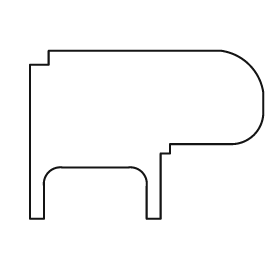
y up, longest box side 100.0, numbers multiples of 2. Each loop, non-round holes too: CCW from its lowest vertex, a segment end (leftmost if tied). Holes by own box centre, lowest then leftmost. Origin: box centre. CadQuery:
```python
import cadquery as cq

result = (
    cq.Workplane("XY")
    .moveTo(-50.0, -36.0)
    .lineTo(-44.0, -36.0)
    .lineTo(-44.0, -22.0)
    .threePointArc((-42.0, -16.0), (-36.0, -14.0))
    .lineTo(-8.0, -14.0)
    .threePointArc((-2.0, -16.0), (0.0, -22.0))
    .lineTo(0.0, -36.0)
    .lineTo(6.0, -36.0)
    .lineTo(6.0, -8.0)
    .lineTo(10.0, -8.0)
    .lineTo(10.0, -4.0)
    .lineTo(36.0, -4.0)
    .threePointArc((46.0, 0.0), (50.0, 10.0))
    .lineTo(50.0, 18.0)
    .threePointArc((44.0, 30.0), (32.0, 36.0))
    .lineTo(-42.0, 36.0)
    .lineTo(-42.0, 30.0)
    .lineTo(-50.0, 30.0)
    .close()
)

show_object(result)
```